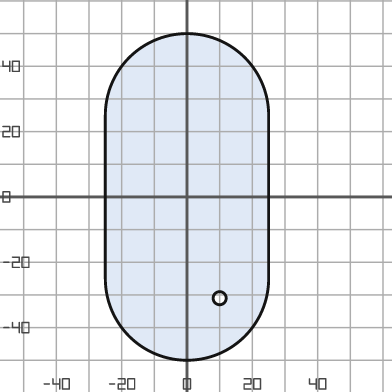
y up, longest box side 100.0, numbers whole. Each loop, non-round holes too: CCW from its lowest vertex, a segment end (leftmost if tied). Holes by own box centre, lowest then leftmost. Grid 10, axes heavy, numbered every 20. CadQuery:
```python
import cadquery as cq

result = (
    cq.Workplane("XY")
    .moveTo(-25.0, -25.0)
    .threePointArc((0.0, -50.0), (25.0, -25.0))
    .lineTo(25.0, 25.0)
    .threePointArc((0.0, 50.0), (-25.0, 25.0))
    .close()
    .moveTo(10.0, -31.0)
    .circle(2.0)
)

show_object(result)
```